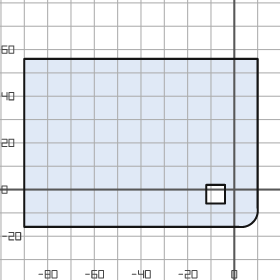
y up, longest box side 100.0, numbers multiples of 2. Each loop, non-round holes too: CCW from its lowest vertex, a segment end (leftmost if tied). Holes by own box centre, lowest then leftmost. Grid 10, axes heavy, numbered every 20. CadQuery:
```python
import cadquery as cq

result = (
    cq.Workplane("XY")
    .moveTo(-90.0, -16.0)
    .lineTo(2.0, -16.0)
    .threePointArc((8.0, -14.0), (10.0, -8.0))
    .lineTo(10.0, 56.0)
    .lineTo(-90.0, 56.0)
    .close()
    .moveTo(-12.0, -6.0)
    .lineTo(-4.0, -6.0)
    .lineTo(-4.0, 2.0)
    .lineTo(-12.0, 2.0)
    .close()
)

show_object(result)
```